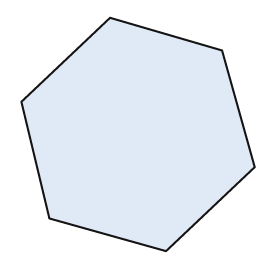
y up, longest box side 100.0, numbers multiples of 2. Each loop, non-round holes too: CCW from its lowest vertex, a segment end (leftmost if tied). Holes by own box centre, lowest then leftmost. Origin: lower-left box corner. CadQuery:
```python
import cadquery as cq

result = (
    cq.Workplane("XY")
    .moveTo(62.0, 0.0)
    .lineTo(100.0, 36.0)
    .lineTo(86.0, 86.0)
    .lineTo(38.0, 100.0)
    .lineTo(0.0, 64.0)
    .lineTo(12.0, 14.0)
    .close()
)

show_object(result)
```